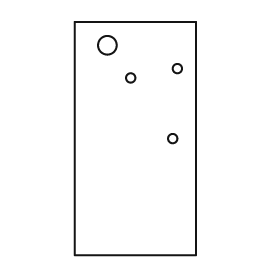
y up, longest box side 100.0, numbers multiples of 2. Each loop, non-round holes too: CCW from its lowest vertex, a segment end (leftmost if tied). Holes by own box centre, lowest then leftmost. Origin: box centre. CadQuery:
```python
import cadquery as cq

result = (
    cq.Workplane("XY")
    .moveTo(-26.0, -50.0)
    .lineTo(26.0, -50.0)
    .lineTo(26.0, 50.0)
    .lineTo(-26.0, 50.0)
    .close()
    .moveTo(16.0, 0.0)
    .circle(2.0)
    .moveTo(-2.0, 26.0)
    .circle(2.0)
    .moveTo(18.0, 30.0)
    .circle(2.0)
    .moveTo(-12.0, 40.0)
    .circle(4.0)
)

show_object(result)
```